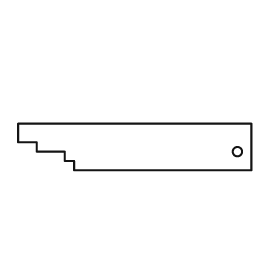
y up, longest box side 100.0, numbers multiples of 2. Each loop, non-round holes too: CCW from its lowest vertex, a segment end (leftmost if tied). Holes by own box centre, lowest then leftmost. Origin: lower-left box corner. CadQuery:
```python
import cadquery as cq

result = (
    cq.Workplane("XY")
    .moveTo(24.0, 0.0)
    .lineTo(100.0, 0.0)
    .lineTo(100.0, 20.0)
    .lineTo(0.0, 20.0)
    .lineTo(0.0, 12.0)
    .lineTo(8.0, 12.0)
    .lineTo(8.0, 8.0)
    .lineTo(20.0, 8.0)
    .lineTo(20.0, 4.0)
    .lineTo(24.0, 4.0)
    .close()
    .moveTo(94.0, 8.0)
    .circle(2.0)
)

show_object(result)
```